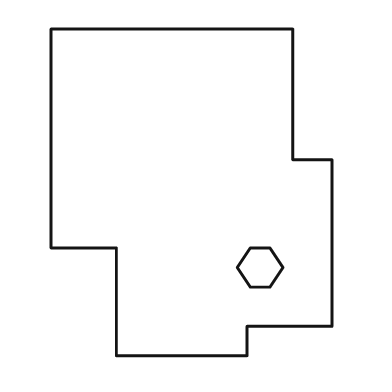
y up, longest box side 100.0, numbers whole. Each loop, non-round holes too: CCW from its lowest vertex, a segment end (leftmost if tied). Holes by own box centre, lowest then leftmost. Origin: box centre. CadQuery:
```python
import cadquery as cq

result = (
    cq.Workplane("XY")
    .moveTo(-23.0, -50.0)
    .lineTo(17.0, -50.0)
    .lineTo(17.0, -41.0)
    .lineTo(43.0, -41.0)
    .lineTo(43.0, 10.0)
    .lineTo(31.0, 10.0)
    .lineTo(31.0, 50.0)
    .lineTo(-43.0, 50.0)
    .lineTo(-43.0, -17.0)
    .lineTo(-23.0, -17.0)
    .close()
    .moveTo(18.0, -29.0)
    .lineTo(24.0, -29.0)
    .lineTo(28.0, -23.0)
    .lineTo(24.0, -17.0)
    .lineTo(18.0, -17.0)
    .lineTo(14.0, -23.0)
    .close()
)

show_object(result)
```